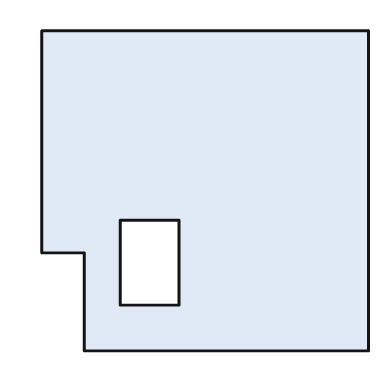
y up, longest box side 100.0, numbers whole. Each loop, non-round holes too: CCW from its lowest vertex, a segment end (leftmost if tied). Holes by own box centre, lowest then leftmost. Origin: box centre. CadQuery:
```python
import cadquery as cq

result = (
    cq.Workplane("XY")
    .moveTo(-37.0, -49.0)
    .lineTo(50.0, -49.0)
    .lineTo(50.0, 49.0)
    .lineTo(-50.0, 49.0)
    .lineTo(-50.0, -19.0)
    .lineTo(-37.0, -19.0)
    .close()
    .moveTo(-26.0, -35.0)
    .lineTo(-8.0, -35.0)
    .lineTo(-8.0, -9.0)
    .lineTo(-26.0, -9.0)
    .close()
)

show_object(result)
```